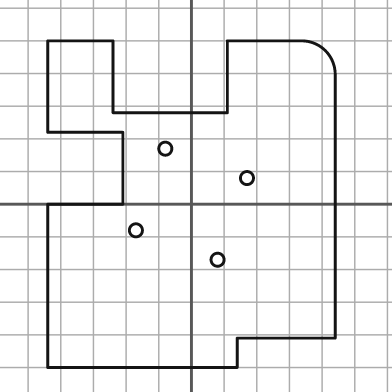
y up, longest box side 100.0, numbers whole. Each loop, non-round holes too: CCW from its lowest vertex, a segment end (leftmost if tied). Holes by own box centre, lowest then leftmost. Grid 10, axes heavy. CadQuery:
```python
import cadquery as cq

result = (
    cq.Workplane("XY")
    .moveTo(-44.0, -50.0)
    .lineTo(14.0, -50.0)
    .lineTo(14.0, -41.0)
    .lineTo(44.0, -41.0)
    .lineTo(44.0, 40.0)
    .threePointArc((41.0, 47.0), (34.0, 50.0))
    .lineTo(11.0, 50.0)
    .lineTo(11.0, 28.0)
    .lineTo(-24.0, 28.0)
    .lineTo(-24.0, 50.0)
    .lineTo(-44.0, 50.0)
    .lineTo(-44.0, 22.0)
    .lineTo(-21.0, 22.0)
    .lineTo(-21.0, 0.0)
    .lineTo(-44.0, 0.0)
    .close()
    .moveTo(8.0, -17.0)
    .circle(2.0)
    .moveTo(-17.0, -8.0)
    .circle(2.0)
    .moveTo(17.0, 8.0)
    .circle(2.0)
    .moveTo(-8.0, 17.0)
    .circle(2.0)
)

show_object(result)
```